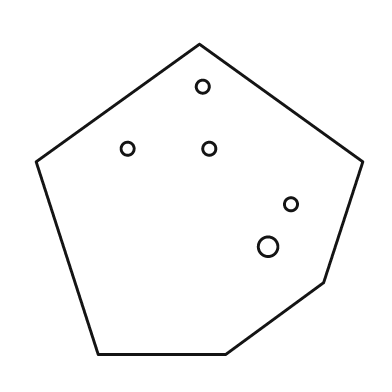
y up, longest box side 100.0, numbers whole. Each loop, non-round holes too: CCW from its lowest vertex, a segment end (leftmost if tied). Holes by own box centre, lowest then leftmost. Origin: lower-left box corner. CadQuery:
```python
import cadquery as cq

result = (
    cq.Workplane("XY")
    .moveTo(19.0, 0.0)
    .lineTo(58.0, 0.0)
    .lineTo(88.0, 22.0)
    .lineTo(100.0, 59.0)
    .lineTo(50.0, 95.0)
    .lineTo(0.0, 59.0)
    .close()
    .moveTo(71.0, 33.0)
    .circle(3.0)
    .moveTo(78.0, 46.0)
    .circle(2.0)
    .moveTo(28.0, 63.0)
    .circle(2.0)
    .moveTo(53.0, 63.0)
    .circle(2.0)
    .moveTo(51.0, 82.0)
    .circle(2.0)
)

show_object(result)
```